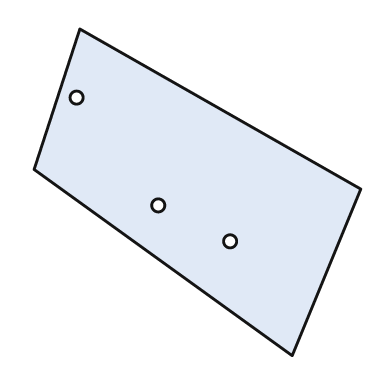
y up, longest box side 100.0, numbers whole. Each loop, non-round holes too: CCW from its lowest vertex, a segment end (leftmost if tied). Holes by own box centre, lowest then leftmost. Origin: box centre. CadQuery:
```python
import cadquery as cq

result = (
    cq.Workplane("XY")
    .moveTo(29.0, -50.0)
    .lineTo(50.0, 1.0)
    .lineTo(-36.0, 50.0)
    .lineTo(-50.0, 7.0)
    .close()
    .moveTo(10.0, -15.0)
    .circle(2.0)
    .moveTo(-12.0, -4.0)
    .circle(2.0)
    .moveTo(-37.0, 29.0)
    .circle(2.0)
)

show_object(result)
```